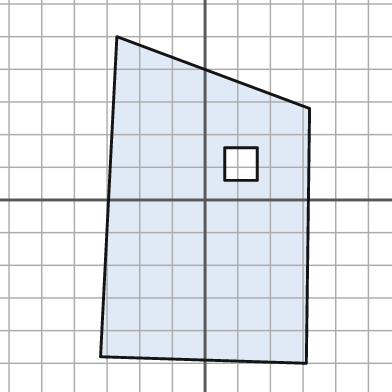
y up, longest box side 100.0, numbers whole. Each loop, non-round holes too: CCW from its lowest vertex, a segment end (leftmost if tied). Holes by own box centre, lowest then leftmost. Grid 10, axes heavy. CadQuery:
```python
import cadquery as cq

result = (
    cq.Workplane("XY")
    .moveTo(31.0, -50.0)
    .lineTo(32.0, 28.0)
    .lineTo(-27.0, 50.0)
    .lineTo(-32.0, -48.0)
    .close()
    .moveTo(6.0, 6.0)
    .lineTo(16.0, 6.0)
    .lineTo(16.0, 16.0)
    .lineTo(6.0, 16.0)
    .close()
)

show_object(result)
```